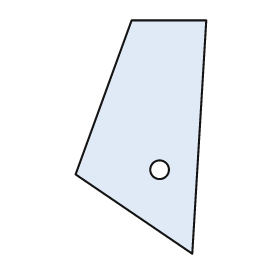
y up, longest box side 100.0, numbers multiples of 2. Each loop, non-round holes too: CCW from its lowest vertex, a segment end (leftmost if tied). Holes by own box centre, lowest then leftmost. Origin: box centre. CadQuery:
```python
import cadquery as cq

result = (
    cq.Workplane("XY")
    .moveTo(22.0, -50.0)
    .lineTo(28.0, 50.0)
    .lineTo(-4.0, 50.0)
    .lineTo(-28.0, -16.0)
    .close()
    .moveTo(8.0, -14.0)
    .circle(4.0)
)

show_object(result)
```